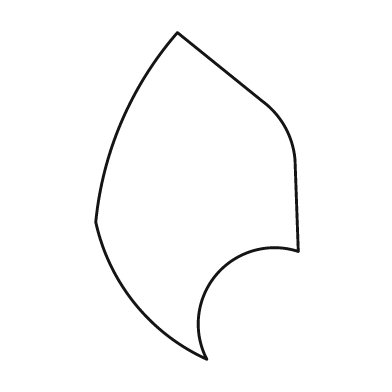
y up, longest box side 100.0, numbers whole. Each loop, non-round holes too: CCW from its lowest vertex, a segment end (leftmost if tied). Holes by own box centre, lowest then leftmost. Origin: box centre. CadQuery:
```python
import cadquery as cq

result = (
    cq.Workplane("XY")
    .moveTo(3.0, -50.0)
    .threePointArc((6.0, -24.0), (31.0, -17.0))
    .lineTo(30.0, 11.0)
    .threePointArc((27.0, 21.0), (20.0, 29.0))
    .lineTo(-6.0, 50.0)
    .threePointArc((-23.0, 23.0), (-31.0, -8.0))
    .threePointArc((-19.0, -33.0), (3.0, -50.0))
    .close()
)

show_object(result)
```